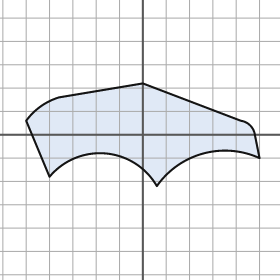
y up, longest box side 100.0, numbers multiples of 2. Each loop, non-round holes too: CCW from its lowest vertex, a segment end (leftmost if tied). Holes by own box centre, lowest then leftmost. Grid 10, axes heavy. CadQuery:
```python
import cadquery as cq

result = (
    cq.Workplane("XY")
    .moveTo(6.0, -22.0)
    .threePointArc((26.0, -8.0), (50.0, -10.0))
    .lineTo(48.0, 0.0)
    .threePointArc((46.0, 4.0), (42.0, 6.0))
    .lineTo(0.0, 22.0)
    .lineTo(-36.0, 16.0)
    .threePointArc((-44.0, 12.0), (-50.0, 6.0))
    .lineTo(-40.0, -18.0)
    .threePointArc((-16.0, -8.0), (6.0, -22.0))
    .close()
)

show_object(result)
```